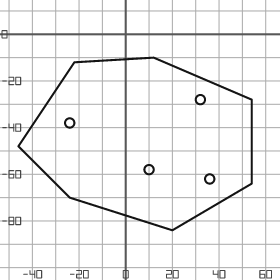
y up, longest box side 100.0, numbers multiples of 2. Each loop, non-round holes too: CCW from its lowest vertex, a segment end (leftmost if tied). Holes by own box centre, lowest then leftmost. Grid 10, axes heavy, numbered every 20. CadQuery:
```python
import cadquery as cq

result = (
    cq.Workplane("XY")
    .moveTo(20.0, -84.0)
    .lineTo(54.0, -64.0)
    .lineTo(54.0, -28.0)
    .lineTo(12.0, -10.0)
    .lineTo(-22.0, -12.0)
    .lineTo(-46.0, -48.0)
    .lineTo(-24.0, -70.0)
    .close()
    .moveTo(36.0, -62.0)
    .circle(2.0)
    .moveTo(10.0, -58.0)
    .circle(2.0)
    .moveTo(-24.0, -38.0)
    .circle(2.0)
    .moveTo(32.0, -28.0)
    .circle(2.0)
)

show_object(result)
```